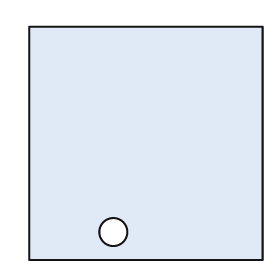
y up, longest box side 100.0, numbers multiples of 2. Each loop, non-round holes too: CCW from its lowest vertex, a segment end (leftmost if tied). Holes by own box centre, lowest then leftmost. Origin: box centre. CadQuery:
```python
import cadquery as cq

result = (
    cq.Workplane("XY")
    .moveTo(-50.0, -50.0)
    .lineTo(50.0, -50.0)
    .lineTo(50.0, 50.0)
    .lineTo(-50.0, 50.0)
    .close()
    .moveTo(-14.0, -38.0)
    .circle(6.0)
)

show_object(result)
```